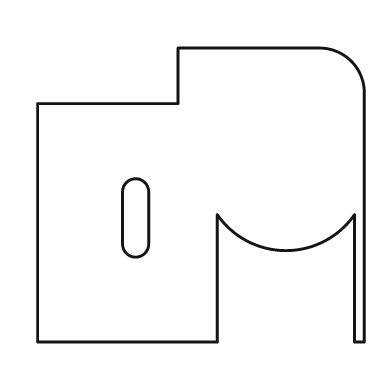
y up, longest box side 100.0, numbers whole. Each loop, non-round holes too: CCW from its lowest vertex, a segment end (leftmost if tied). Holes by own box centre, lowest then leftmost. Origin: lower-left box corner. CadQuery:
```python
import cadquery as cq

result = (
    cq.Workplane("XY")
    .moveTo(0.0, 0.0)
    .lineTo(55.0, 0.0)
    .lineTo(55.0, 39.0)
    .threePointArc((76.0, 28.0), (97.0, 39.0))
    .lineTo(97.0, 0.0)
    .lineTo(100.0, 0.0)
    .lineTo(100.0, 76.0)
    .threePointArc((96.0, 86.0), (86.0, 90.0))
    .lineTo(43.0, 90.0)
    .lineTo(43.0, 73.0)
    .lineTo(0.0, 73.0)
    .close()
    .moveTo(26.0, 30.0)
    .threePointArc((30.0, 26.0), (34.0, 30.0))
    .lineTo(34.0, 46.0)
    .threePointArc((30.0, 50.0), (26.0, 46.0))
    .close()
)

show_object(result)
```